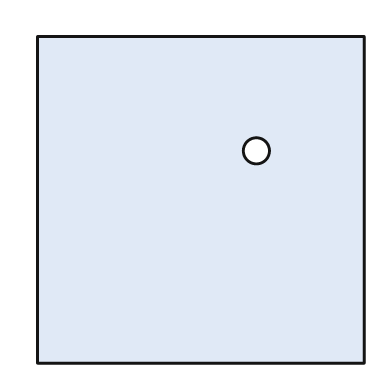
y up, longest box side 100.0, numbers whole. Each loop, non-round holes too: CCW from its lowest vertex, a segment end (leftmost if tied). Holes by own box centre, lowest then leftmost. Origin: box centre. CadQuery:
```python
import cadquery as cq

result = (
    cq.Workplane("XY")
    .moveTo(-50.0, -50.0)
    .lineTo(50.0, -50.0)
    .lineTo(50.0, 50.0)
    .lineTo(-50.0, 50.0)
    .close()
    .moveTo(17.0, 15.0)
    .circle(4.0)
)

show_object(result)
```